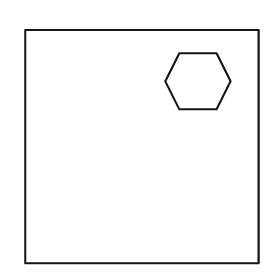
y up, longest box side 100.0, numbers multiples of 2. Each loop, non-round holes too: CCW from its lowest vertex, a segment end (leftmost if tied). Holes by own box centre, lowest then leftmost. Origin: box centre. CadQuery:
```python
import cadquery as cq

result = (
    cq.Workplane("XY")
    .moveTo(-50.0, -50.0)
    .lineTo(50.0, -50.0)
    .lineTo(50.0, 50.0)
    .lineTo(-50.0, 50.0)
    .close()
    .moveTo(16.0, 16.0)
    .lineTo(32.0, 16.0)
    .lineTo(38.0, 28.0)
    .lineTo(32.0, 40.0)
    .lineTo(16.0, 40.0)
    .lineTo(10.0, 28.0)
    .close()
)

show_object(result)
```